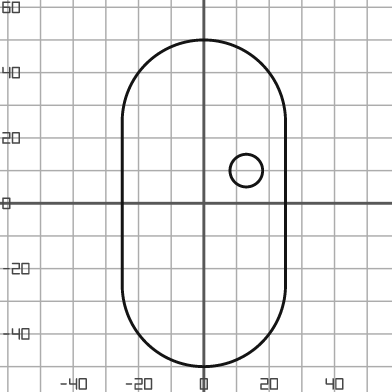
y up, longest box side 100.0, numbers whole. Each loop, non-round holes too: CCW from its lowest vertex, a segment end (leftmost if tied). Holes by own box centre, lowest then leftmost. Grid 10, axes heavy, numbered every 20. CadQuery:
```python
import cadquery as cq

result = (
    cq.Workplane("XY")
    .moveTo(-25.0, -25.0)
    .threePointArc((0.0, -50.0), (25.0, -25.0))
    .lineTo(25.0, 25.0)
    .threePointArc((0.0, 50.0), (-25.0, 25.0))
    .close()
    .moveTo(13.0, 10.0)
    .circle(5.0)
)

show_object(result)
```